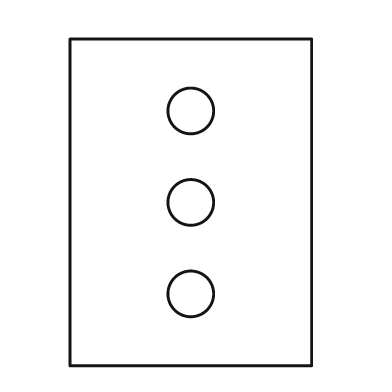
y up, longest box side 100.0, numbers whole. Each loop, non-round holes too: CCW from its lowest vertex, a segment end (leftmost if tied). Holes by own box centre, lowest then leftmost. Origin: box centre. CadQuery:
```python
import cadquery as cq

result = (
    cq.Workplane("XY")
    .moveTo(-37.0, -50.0)
    .lineTo(37.0, -50.0)
    .lineTo(37.0, 50.0)
    .lineTo(-37.0, 50.0)
    .close()
    .moveTo(0.0, -28.0)
    .circle(7.0)
    .moveTo(0.0, 0.0)
    .circle(7.0)
    .moveTo(0.0, 28.0)
    .circle(7.0)
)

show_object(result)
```